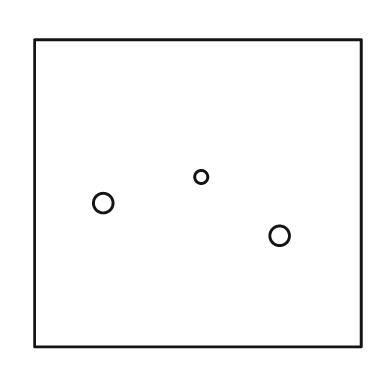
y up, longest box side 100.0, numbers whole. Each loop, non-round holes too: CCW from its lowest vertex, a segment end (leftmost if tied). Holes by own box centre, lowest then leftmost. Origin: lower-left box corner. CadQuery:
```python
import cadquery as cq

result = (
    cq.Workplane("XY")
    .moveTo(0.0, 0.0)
    .lineTo(100.0, 0.0)
    .lineTo(100.0, 94.0)
    .lineTo(0.0, 94.0)
    .close()
    .moveTo(75.0, 34.0)
    .circle(3.0)
    .moveTo(21.0, 44.0)
    .circle(3.0)
    .moveTo(51.0, 52.0)
    .circle(2.0)
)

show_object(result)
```